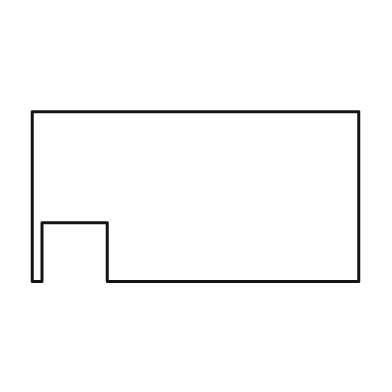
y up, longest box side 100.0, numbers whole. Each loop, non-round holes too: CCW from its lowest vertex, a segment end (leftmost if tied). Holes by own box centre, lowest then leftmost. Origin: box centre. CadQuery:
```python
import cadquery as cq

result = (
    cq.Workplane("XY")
    .moveTo(-50.0, -26.0)
    .lineTo(-47.0, -26.0)
    .lineTo(-47.0, -8.0)
    .lineTo(-27.0, -8.0)
    .lineTo(-27.0, -26.0)
    .lineTo(50.0, -26.0)
    .lineTo(50.0, 26.0)
    .lineTo(-50.0, 26.0)
    .close()
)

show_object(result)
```